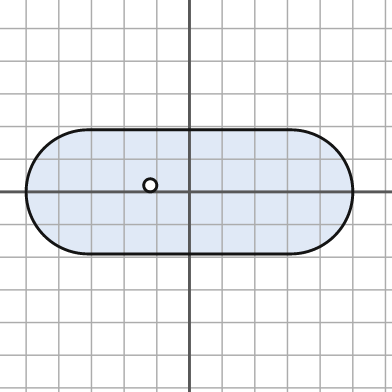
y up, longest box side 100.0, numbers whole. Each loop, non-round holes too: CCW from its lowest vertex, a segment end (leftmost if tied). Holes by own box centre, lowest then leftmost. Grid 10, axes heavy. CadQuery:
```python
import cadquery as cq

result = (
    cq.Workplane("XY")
    .moveTo(-31.0, -19.0)
    .lineTo(31.0, -19.0)
    .threePointArc((50.0, 0.0), (31.0, 19.0))
    .lineTo(-31.0, 19.0)
    .threePointArc((-50.0, 0.0), (-31.0, -19.0))
    .close()
    .moveTo(-12.0, 2.0)
    .circle(2.0)
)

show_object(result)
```